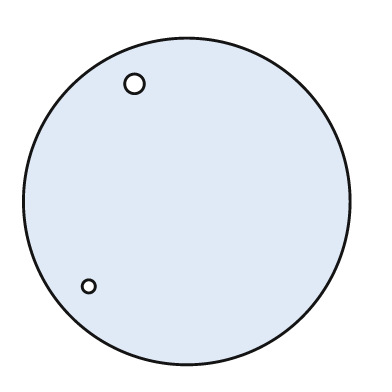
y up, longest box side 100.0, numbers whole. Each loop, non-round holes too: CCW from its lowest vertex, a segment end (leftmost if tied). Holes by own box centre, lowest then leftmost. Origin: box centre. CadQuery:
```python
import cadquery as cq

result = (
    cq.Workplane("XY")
    .moveTo(0.0, 0.0)
    .circle(50.0)
    .moveTo(-30.0, -26.0)
    .circle(2.0)
    .moveTo(-16.0, 36.0)
    .circle(3.0)
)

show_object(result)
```